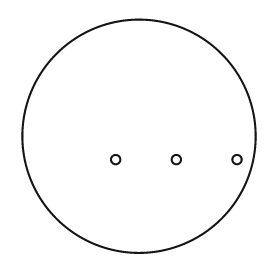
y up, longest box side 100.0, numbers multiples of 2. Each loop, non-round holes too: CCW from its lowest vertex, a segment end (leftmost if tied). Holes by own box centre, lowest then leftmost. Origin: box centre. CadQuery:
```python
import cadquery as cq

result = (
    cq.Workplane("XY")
    .moveTo(0.0, 0.0)
    .circle(50.0)
    .moveTo(-10.0, -10.0)
    .circle(2.0)
    .moveTo(16.0, -10.0)
    .circle(2.0)
    .moveTo(42.0, -10.0)
    .circle(2.0)
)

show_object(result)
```